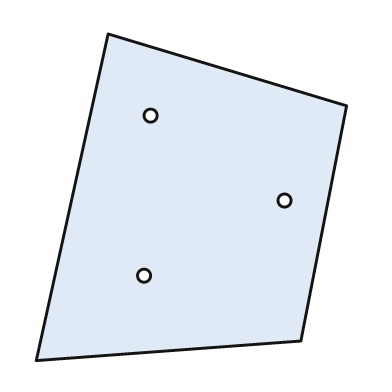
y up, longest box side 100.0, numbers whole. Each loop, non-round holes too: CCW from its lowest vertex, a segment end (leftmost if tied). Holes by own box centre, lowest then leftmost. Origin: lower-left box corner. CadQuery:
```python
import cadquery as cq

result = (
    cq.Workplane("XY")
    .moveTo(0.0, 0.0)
    .lineTo(81.0, 6.0)
    .lineTo(95.0, 78.0)
    .lineTo(22.0, 100.0)
    .close()
    .moveTo(33.0, 26.0)
    .circle(2.0)
    .moveTo(76.0, 49.0)
    .circle(2.0)
    .moveTo(35.0, 75.0)
    .circle(2.0)
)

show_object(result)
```